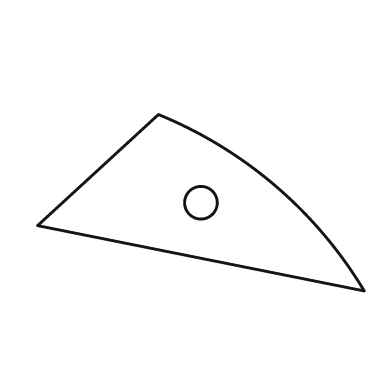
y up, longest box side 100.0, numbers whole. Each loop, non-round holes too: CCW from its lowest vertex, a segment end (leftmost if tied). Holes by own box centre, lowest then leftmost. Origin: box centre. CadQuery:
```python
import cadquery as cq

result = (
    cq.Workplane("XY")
    .moveTo(50.0, -27.0)
    .threePointArc((23.0, 5.0), (-13.0, 27.0))
    .lineTo(-50.0, -7.0)
    .close()
    .moveTo(0.0, 0.0)
    .circle(5.0)
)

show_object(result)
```